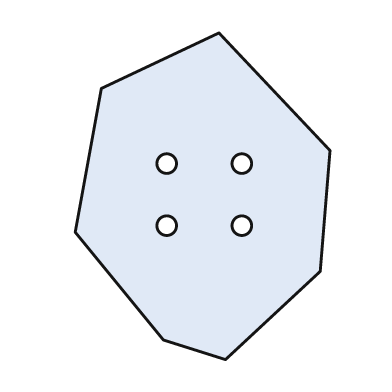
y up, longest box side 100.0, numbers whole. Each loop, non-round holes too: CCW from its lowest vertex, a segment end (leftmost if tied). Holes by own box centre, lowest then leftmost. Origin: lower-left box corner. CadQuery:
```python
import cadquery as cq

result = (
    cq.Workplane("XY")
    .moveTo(46.0, 0.0)
    .lineTo(75.0, 27.0)
    .lineTo(78.0, 64.0)
    .lineTo(44.0, 100.0)
    .lineTo(8.0, 83.0)
    .lineTo(0.0, 39.0)
    .lineTo(27.0, 6.0)
    .close()
    .moveTo(28.0, 41.0)
    .circle(3.0)
    .moveTo(51.0, 41.0)
    .circle(3.0)
    .moveTo(28.0, 60.0)
    .circle(3.0)
    .moveTo(51.0, 60.0)
    .circle(3.0)
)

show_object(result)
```